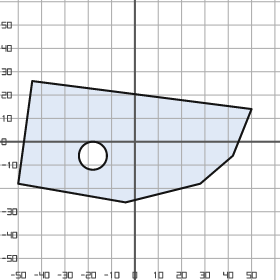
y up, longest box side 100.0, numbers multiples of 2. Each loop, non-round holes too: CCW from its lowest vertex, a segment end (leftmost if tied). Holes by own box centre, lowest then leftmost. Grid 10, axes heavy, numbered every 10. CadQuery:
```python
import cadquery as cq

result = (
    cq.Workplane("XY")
    .moveTo(-4.0, -26.0)
    .lineTo(28.0, -18.0)
    .lineTo(42.0, -6.0)
    .lineTo(50.0, 14.0)
    .lineTo(-44.0, 26.0)
    .lineTo(-50.0, -18.0)
    .close()
    .moveTo(-18.0, -6.0)
    .circle(6.0)
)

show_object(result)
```